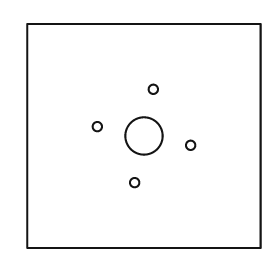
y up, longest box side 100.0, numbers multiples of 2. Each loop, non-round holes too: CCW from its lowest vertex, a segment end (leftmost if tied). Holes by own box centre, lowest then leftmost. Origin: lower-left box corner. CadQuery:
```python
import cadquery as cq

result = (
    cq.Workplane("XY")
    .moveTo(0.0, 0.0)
    .lineTo(100.0, 0.0)
    .lineTo(100.0, 96.0)
    .lineTo(0.0, 96.0)
    .close()
    .moveTo(46.0, 28.0)
    .circle(2.0)
    .moveTo(70.0, 44.0)
    .circle(2.0)
    .moveTo(50.0, 48.0)
    .circle(8.0)
    .moveTo(30.0, 52.0)
    .circle(2.0)
    .moveTo(54.0, 68.0)
    .circle(2.0)
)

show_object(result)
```